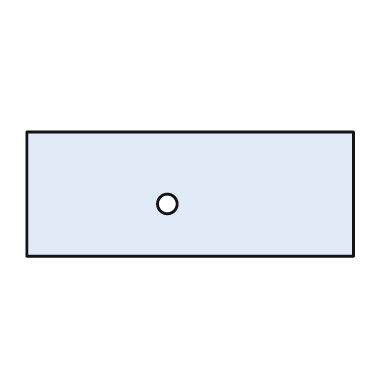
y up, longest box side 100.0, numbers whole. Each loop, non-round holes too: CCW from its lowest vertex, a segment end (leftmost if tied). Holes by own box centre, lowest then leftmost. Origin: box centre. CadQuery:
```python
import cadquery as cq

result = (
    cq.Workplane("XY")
    .moveTo(-50.0, -19.0)
    .lineTo(50.0, -19.0)
    .lineTo(50.0, 19.0)
    .lineTo(-50.0, 19.0)
    .close()
    .moveTo(-7.0, -3.0)
    .circle(3.0)
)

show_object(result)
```